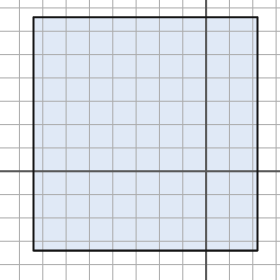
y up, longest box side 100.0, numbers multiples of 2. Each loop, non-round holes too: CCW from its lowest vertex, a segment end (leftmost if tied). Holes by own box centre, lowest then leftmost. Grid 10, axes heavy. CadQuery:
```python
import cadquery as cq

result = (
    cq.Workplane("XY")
    .moveTo(-74.0, -34.0)
    .lineTo(22.0, -34.0)
    .lineTo(22.0, 66.0)
    .lineTo(-74.0, 66.0)
    .close()
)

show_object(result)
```